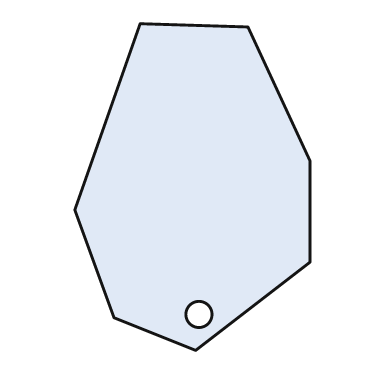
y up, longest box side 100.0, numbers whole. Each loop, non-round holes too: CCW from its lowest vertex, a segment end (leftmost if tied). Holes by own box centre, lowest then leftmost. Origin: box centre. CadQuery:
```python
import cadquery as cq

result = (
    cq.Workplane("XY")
    .moveTo(1.0, -50.0)
    .lineTo(36.0, -23.0)
    .lineTo(36.0, 8.0)
    .lineTo(17.0, 49.0)
    .lineTo(-16.0, 50.0)
    .lineTo(-36.0, -7.0)
    .lineTo(-24.0, -40.0)
    .close()
    .moveTo(2.0, -39.0)
    .circle(4.0)
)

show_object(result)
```